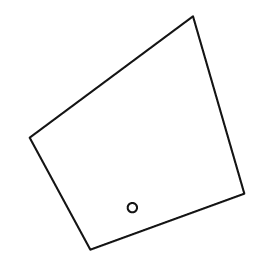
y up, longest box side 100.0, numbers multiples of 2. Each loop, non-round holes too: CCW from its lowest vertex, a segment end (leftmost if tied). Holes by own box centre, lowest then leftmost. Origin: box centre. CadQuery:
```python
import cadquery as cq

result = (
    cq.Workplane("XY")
    .moveTo(-20.0, -50.0)
    .lineTo(46.0, -26.0)
    .lineTo(24.0, 50.0)
    .lineTo(-46.0, -2.0)
    .close()
    .moveTo(-2.0, -32.0)
    .circle(2.0)
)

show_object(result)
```